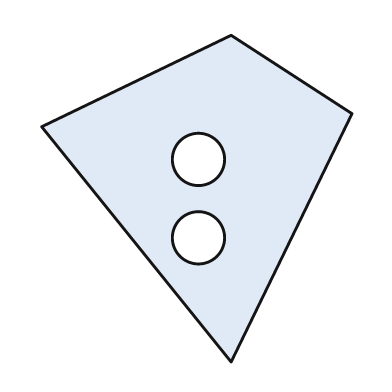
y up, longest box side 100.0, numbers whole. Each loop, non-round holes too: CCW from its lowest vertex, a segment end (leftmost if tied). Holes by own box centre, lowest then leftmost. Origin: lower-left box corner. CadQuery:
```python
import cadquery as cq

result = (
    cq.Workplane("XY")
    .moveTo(58.0, 0.0)
    .lineTo(95.0, 76.0)
    .lineTo(58.0, 100.0)
    .lineTo(0.0, 72.0)
    .close()
    .moveTo(48.0, 38.0)
    .circle(8.0)
    .moveTo(48.0, 62.0)
    .circle(8.0)
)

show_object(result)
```